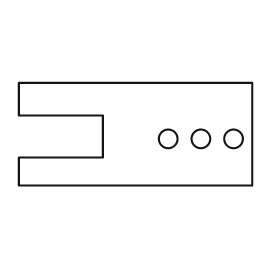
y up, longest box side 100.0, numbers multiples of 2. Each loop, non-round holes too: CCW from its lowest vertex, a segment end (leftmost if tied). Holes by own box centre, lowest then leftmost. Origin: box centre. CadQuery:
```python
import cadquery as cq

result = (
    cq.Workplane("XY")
    .moveTo(-50.0, -22.0)
    .lineTo(50.0, -22.0)
    .lineTo(50.0, 22.0)
    .lineTo(-50.0, 22.0)
    .lineTo(-50.0, 8.0)
    .lineTo(-14.0, 8.0)
    .lineTo(-14.0, -10.0)
    .lineTo(-50.0, -10.0)
    .close()
    .moveTo(14.0, -2.0)
    .circle(4.0)
    .moveTo(28.0, -2.0)
    .circle(4.0)
    .moveTo(42.0, -2.0)
    .circle(4.0)
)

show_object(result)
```